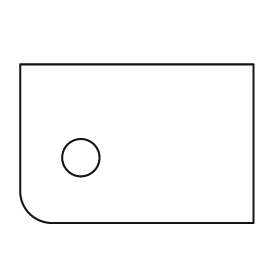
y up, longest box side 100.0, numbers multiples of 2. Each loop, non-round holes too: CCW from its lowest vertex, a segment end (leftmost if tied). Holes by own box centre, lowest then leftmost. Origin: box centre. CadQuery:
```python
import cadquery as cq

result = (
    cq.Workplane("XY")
    .moveTo(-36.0, -34.0)
    .lineTo(50.0, -34.0)
    .lineTo(50.0, 34.0)
    .lineTo(-50.0, 34.0)
    .lineTo(-50.0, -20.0)
    .threePointArc((-46.0, -30.0), (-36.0, -34.0))
    .close()
    .moveTo(-24.0, -6.0)
    .circle(8.0)
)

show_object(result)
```